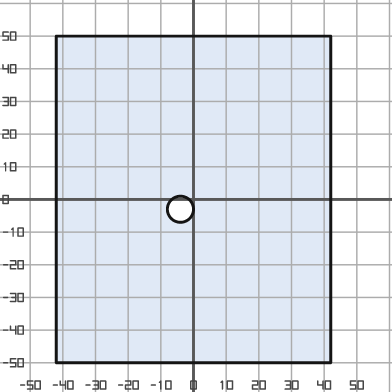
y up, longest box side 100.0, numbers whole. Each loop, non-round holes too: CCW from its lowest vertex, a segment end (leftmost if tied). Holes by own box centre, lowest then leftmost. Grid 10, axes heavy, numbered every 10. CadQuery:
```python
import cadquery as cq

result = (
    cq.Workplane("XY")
    .moveTo(-42.0, -50.0)
    .lineTo(42.0, -50.0)
    .lineTo(42.0, 50.0)
    .lineTo(-42.0, 50.0)
    .close()
    .moveTo(-4.0, -3.0)
    .circle(4.0)
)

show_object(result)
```